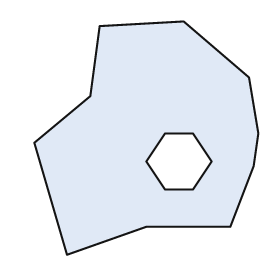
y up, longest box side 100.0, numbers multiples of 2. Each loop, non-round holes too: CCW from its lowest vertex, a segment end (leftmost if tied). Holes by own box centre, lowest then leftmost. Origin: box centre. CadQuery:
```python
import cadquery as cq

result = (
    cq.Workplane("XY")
    .moveTo(-34.0, -50.0)
    .lineTo(0.0, -38.0)
    .lineTo(36.0, -38.0)
    .lineTo(46.0, -12.0)
    .lineTo(48.0, 2.0)
    .lineTo(44.0, 26.0)
    .lineTo(16.0, 50.0)
    .lineTo(-20.0, 48.0)
    .lineTo(-24.0, 18.0)
    .lineTo(-48.0, -2.0)
    .close()
    .moveTo(8.0, -22.0)
    .lineTo(20.0, -22.0)
    .lineTo(28.0, -10.0)
    .lineTo(20.0, 2.0)
    .lineTo(8.0, 2.0)
    .lineTo(0.0, -10.0)
    .close()
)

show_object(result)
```